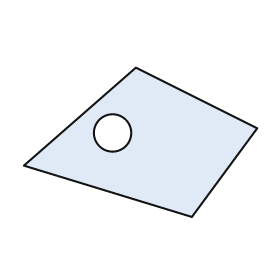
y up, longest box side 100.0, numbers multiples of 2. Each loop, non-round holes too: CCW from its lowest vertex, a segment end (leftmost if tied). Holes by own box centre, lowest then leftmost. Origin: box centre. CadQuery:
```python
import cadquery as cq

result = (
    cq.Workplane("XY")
    .moveTo(22.0, -32.0)
    .lineTo(50.0, 6.0)
    .lineTo(-2.0, 32.0)
    .lineTo(-50.0, -10.0)
    .close()
    .moveTo(-12.0, 4.0)
    .circle(8.0)
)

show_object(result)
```